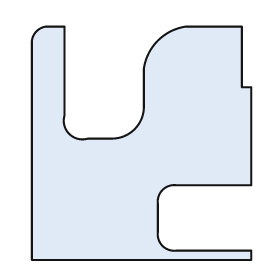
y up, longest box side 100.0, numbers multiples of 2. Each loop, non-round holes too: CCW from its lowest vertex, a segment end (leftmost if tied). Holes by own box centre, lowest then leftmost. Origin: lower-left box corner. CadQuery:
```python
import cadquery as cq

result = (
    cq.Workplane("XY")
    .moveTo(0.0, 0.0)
    .lineTo(94.0, 0.0)
    .lineTo(94.0, 4.0)
    .lineTo(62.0, 4.0)
    .threePointArc((56.0, 6.0), (54.0, 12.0))
    .lineTo(54.0, 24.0)
    .threePointArc((56.0, 30.0), (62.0, 32.0))
    .lineTo(94.0, 32.0)
    .lineTo(94.0, 74.0)
    .lineTo(90.0, 74.0)
    .lineTo(90.0, 100.0)
    .lineTo(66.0, 100.0)
    .threePointArc((54.0, 94.0), (48.0, 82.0))
    .lineTo(48.0, 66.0)
    .threePointArc((44.0, 56.0), (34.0, 52.0))
    .lineTo(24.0, 52.0)
    .threePointArc((16.0, 54.0), (14.0, 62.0))
    .lineTo(14.0, 100.0)
    .lineTo(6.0, 100.0)
    .threePointArc((2.0, 98.0), (0.0, 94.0))
    .close()
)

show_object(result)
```